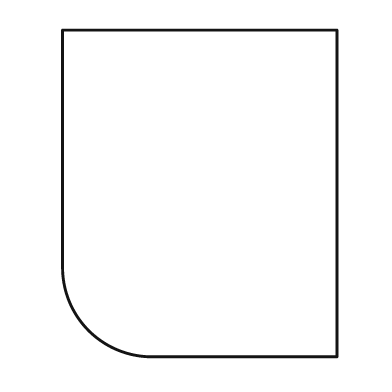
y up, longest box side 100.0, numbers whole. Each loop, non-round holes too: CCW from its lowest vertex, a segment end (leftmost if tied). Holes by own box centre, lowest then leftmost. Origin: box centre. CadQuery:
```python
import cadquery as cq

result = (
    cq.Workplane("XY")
    .moveTo(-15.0, -50.0)
    .lineTo(42.0, -50.0)
    .lineTo(42.0, 50.0)
    .lineTo(-42.0, 50.0)
    .lineTo(-42.0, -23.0)
    .threePointArc((-34.0, -42.0), (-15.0, -50.0))
    .close()
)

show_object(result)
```